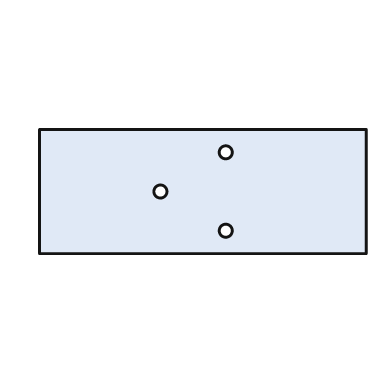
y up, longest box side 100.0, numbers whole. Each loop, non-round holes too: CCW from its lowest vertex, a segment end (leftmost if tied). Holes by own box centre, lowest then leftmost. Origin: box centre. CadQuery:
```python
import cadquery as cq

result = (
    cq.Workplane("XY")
    .moveTo(-50.0, -19.0)
    .lineTo(50.0, -19.0)
    .lineTo(50.0, 19.0)
    .lineTo(-50.0, 19.0)
    .close()
    .moveTo(7.0, -12.0)
    .circle(2.0)
    .moveTo(-13.0, 0.0)
    .circle(2.0)
    .moveTo(7.0, 12.0)
    .circle(2.0)
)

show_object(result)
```